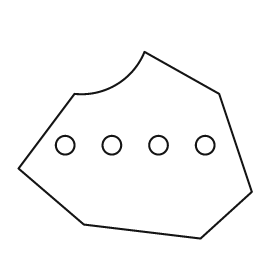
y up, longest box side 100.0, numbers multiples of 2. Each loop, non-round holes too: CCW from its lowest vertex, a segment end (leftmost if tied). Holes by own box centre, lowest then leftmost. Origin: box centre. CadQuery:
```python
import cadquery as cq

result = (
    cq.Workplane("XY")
    .moveTo(28.0, -40.0)
    .lineTo(50.0, -20.0)
    .lineTo(36.0, 22.0)
    .lineTo(4.0, 40.0)
    .threePointArc((-8.0, 26.0), (-26.0, 22.0))
    .lineTo(-50.0, -10.0)
    .lineTo(-22.0, -34.0)
    .close()
    .moveTo(-30.0, 0.0)
    .circle(4.0)
    .moveTo(-10.0, 0.0)
    .circle(4.0)
    .moveTo(10.0, 0.0)
    .circle(4.0)
    .moveTo(30.0, 0.0)
    .circle(4.0)
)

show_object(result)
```